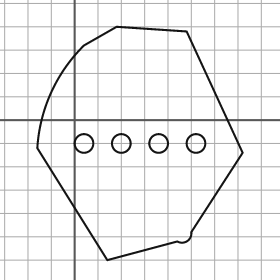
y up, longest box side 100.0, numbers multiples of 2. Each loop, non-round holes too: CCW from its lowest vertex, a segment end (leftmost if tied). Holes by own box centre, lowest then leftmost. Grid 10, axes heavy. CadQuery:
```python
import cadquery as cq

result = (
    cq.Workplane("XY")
    .moveTo(14.0, -60.0)
    .lineTo(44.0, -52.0)
    .threePointArc((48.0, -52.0), (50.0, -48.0))
    .lineTo(72.0, -14.0)
    .lineTo(48.0, 38.0)
    .lineTo(18.0, 40.0)
    .lineTo(4.0, 32.0)
    .threePointArc((-10.0, 12.0), (-16.0, -12.0))
    .close()
    .moveTo(4.0, -10.0)
    .circle(4.0)
    .moveTo(20.0, -10.0)
    .circle(4.0)
    .moveTo(36.0, -10.0)
    .circle(4.0)
    .moveTo(52.0, -10.0)
    .circle(4.0)
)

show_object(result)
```